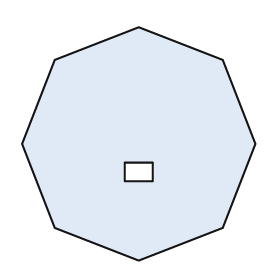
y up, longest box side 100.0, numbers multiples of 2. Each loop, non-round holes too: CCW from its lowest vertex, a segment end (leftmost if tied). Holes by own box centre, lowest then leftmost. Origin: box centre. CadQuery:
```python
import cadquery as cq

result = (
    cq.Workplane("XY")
    .moveTo(0.0, -50.0)
    .lineTo(36.0, -36.0)
    .lineTo(50.0, 0.0)
    .lineTo(36.0, 36.0)
    .lineTo(0.0, 50.0)
    .lineTo(-36.0, 36.0)
    .lineTo(-50.0, 0.0)
    .lineTo(-36.0, -36.0)
    .close()
    .moveTo(-6.0, -16.0)
    .lineTo(6.0, -16.0)
    .lineTo(6.0, -8.0)
    .lineTo(-6.0, -8.0)
    .close()
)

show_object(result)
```